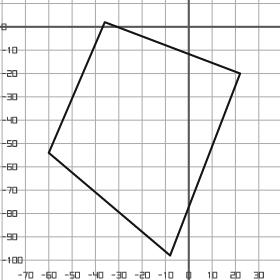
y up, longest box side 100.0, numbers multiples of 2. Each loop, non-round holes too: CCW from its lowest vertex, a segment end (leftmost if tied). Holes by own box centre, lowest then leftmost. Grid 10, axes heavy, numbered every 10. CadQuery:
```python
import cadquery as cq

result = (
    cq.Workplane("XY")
    .moveTo(-8.0, -98.0)
    .lineTo(22.0, -20.0)
    .lineTo(-36.0, 2.0)
    .lineTo(-60.0, -54.0)
    .close()
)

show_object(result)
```